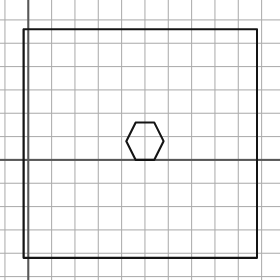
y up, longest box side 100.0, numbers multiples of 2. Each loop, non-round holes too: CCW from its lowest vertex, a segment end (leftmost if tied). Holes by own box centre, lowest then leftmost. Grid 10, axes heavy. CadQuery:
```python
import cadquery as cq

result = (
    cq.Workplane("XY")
    .moveTo(-2.0, -42.0)
    .lineTo(98.0, -42.0)
    .lineTo(98.0, 56.0)
    .lineTo(-2.0, 56.0)
    .close()
    .moveTo(46.0, 0.0)
    .lineTo(54.0, 0.0)
    .lineTo(58.0, 8.0)
    .lineTo(54.0, 16.0)
    .lineTo(46.0, 16.0)
    .lineTo(42.0, 8.0)
    .close()
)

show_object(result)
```